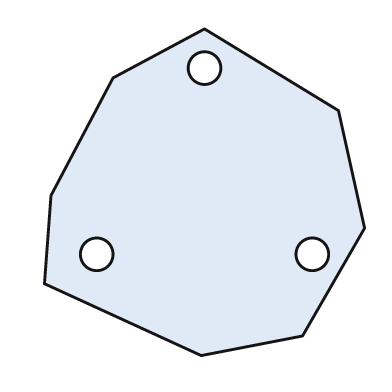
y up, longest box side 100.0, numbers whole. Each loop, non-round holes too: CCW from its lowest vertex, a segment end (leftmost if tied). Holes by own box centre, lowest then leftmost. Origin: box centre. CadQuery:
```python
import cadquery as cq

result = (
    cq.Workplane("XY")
    .moveTo(-1.0, -50.0)
    .lineTo(30.0, -44.0)
    .lineTo(49.0, -11.0)
    .lineTo(41.0, 25.0)
    .lineTo(0.0, 50.0)
    .lineTo(-28.0, 35.0)
    .lineTo(-47.0, -1.0)
    .lineTo(-49.0, -28.0)
    .close()
    .moveTo(-33.0, -19.0)
    .circle(5.0)
    .moveTo(33.0, -19.0)
    .circle(5.0)
    .moveTo(0.0, 38.0)
    .circle(5.0)
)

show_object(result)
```